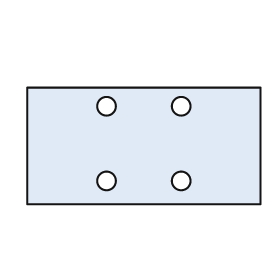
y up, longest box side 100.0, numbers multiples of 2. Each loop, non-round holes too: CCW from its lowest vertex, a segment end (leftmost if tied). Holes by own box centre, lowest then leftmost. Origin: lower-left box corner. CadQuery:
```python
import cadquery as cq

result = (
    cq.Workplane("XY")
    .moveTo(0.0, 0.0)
    .lineTo(100.0, 0.0)
    .lineTo(100.0, 50.0)
    .lineTo(0.0, 50.0)
    .close()
    .moveTo(34.0, 10.0)
    .circle(4.0)
    .moveTo(66.0, 10.0)
    .circle(4.0)
    .moveTo(34.0, 42.0)
    .circle(4.0)
    .moveTo(66.0, 42.0)
    .circle(4.0)
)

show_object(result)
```